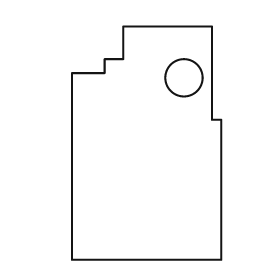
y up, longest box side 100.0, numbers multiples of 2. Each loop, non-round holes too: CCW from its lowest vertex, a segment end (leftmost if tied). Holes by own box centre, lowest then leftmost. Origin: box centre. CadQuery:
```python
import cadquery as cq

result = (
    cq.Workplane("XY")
    .moveTo(-32.0, -50.0)
    .lineTo(32.0, -50.0)
    .lineTo(32.0, 10.0)
    .lineTo(28.0, 10.0)
    .lineTo(28.0, 50.0)
    .lineTo(-10.0, 50.0)
    .lineTo(-10.0, 36.0)
    .lineTo(-18.0, 36.0)
    .lineTo(-18.0, 30.0)
    .lineTo(-32.0, 30.0)
    .close()
    .moveTo(16.0, 28.0)
    .circle(8.0)
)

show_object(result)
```